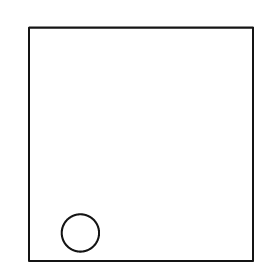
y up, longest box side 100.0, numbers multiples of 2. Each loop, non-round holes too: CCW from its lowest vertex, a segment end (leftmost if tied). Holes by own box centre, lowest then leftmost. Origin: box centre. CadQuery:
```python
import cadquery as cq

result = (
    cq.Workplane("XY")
    .moveTo(-48.0, -50.0)
    .lineTo(48.0, -50.0)
    .lineTo(48.0, 50.0)
    .lineTo(-48.0, 50.0)
    .close()
    .moveTo(-26.0, -38.0)
    .circle(8.0)
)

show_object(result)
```